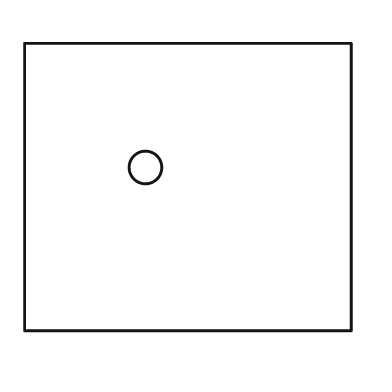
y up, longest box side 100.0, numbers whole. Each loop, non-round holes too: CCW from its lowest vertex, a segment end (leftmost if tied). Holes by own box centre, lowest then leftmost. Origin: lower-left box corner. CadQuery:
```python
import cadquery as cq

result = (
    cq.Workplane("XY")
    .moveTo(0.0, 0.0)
    .lineTo(100.0, 0.0)
    .lineTo(100.0, 88.0)
    .lineTo(0.0, 88.0)
    .close()
    .moveTo(37.0, 50.0)
    .circle(5.0)
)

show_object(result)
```